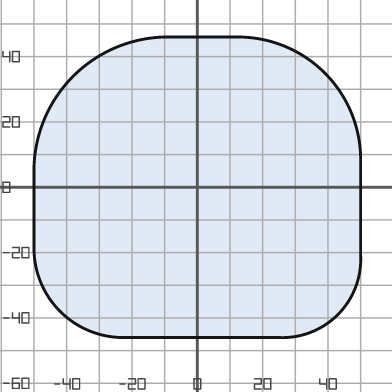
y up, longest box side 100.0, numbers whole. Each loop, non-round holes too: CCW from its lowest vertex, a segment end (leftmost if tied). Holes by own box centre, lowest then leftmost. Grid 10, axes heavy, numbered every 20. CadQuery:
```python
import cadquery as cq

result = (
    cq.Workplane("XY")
    .moveTo(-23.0, -46.0)
    .lineTo(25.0, -46.0)
    .threePointArc((43.0, -39.0), (50.0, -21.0))
    .lineTo(50.0, 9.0)
    .threePointArc((39.0, 35.0), (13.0, 46.0))
    .lineTo(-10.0, 46.0)
    .threePointArc((-38.0, 34.0), (-50.0, 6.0))
    .lineTo(-50.0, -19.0)
    .threePointArc((-42.0, -38.0), (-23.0, -46.0))
    .close()
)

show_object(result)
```